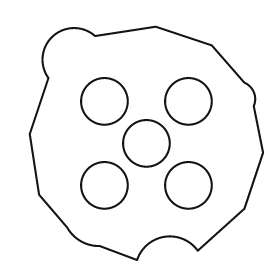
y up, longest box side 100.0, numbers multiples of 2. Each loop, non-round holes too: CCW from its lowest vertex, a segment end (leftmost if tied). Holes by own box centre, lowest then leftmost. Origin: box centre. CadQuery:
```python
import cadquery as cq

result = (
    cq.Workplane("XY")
    .moveTo(-4.0, -50.0)
    .threePointArc((8.0, -40.0), (22.0, -46.0))
    .lineTo(42.0, -28.0)
    .lineTo(50.0, -4.0)
    .lineTo(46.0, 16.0)
    .threePointArc((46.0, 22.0), (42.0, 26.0))
    .lineTo(28.0, 42.0)
    .lineTo(4.0, 50.0)
    .lineTo(-22.0, 46.0)
    .threePointArc((-40.0, 46.0), (-42.0, 28.0))
    .lineTo(-50.0, 4.0)
    .lineTo(-46.0, -22.0)
    .lineTo(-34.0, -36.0)
    .threePointArc((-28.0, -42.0), (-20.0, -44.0))
    .close()
    .moveTo(-18.0, -18.0)
    .circle(10.0)
    .moveTo(18.0, -18.0)
    .circle(10.0)
    .moveTo(0.0, 0.0)
    .circle(10.0)
    .moveTo(-18.0, 18.0)
    .circle(10.0)
    .moveTo(18.0, 18.0)
    .circle(10.0)
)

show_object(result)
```